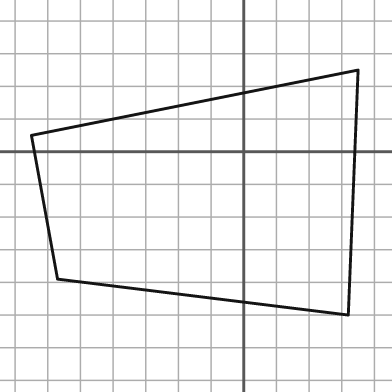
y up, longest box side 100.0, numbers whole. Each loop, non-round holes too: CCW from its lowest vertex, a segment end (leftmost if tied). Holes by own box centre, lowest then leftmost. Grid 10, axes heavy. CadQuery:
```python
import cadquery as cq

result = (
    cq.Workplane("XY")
    .moveTo(32.0, -50.0)
    .lineTo(35.0, 25.0)
    .lineTo(-65.0, 5.0)
    .lineTo(-57.0, -39.0)
    .close()
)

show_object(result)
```